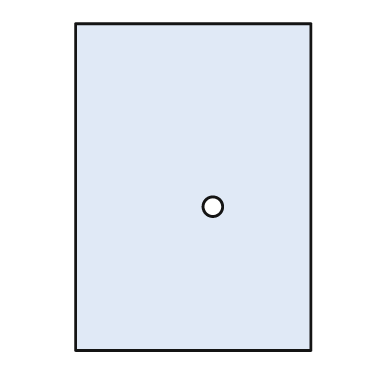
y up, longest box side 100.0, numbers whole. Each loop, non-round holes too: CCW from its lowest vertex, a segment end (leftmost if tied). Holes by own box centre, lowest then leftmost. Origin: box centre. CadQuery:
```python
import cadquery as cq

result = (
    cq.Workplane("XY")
    .moveTo(-36.0, -50.0)
    .lineTo(36.0, -50.0)
    .lineTo(36.0, 50.0)
    .lineTo(-36.0, 50.0)
    .close()
    .moveTo(6.0, -6.0)
    .circle(3.0)
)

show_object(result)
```